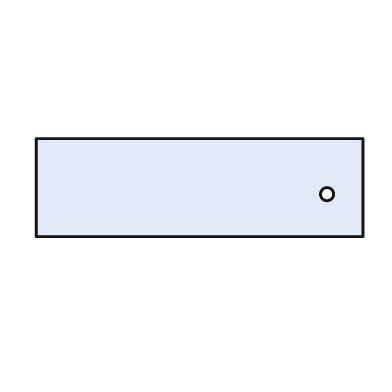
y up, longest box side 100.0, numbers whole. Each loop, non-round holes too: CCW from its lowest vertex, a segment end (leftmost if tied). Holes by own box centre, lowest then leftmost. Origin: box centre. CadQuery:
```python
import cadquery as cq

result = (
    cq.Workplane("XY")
    .moveTo(-50.0, -15.0)
    .lineTo(50.0, -15.0)
    .lineTo(50.0, 15.0)
    .lineTo(-50.0, 15.0)
    .close()
    .moveTo(39.0, -2.0)
    .circle(2.0)
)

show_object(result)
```